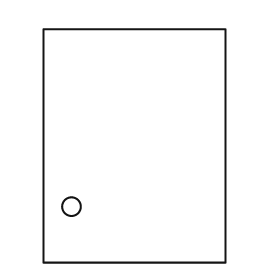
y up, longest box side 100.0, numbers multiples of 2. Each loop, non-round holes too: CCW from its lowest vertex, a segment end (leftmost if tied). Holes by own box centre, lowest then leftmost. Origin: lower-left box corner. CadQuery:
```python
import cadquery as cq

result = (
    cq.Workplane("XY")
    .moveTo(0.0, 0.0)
    .lineTo(78.0, 0.0)
    .lineTo(78.0, 100.0)
    .lineTo(0.0, 100.0)
    .close()
    .moveTo(12.0, 24.0)
    .circle(4.0)
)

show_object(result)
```